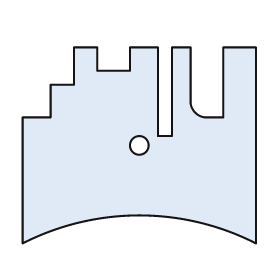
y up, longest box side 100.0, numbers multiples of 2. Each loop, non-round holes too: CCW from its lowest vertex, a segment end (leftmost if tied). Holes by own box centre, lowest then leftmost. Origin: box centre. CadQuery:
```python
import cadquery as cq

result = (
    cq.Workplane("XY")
    .moveTo(-50.0, -42.0)
    .threePointArc((0.0, -30.0), (50.0, -42.0))
    .lineTo(50.0, 42.0)
    .lineTo(36.0, 42.0)
    .lineTo(36.0, 12.0)
    .lineTo(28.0, 12.0)
    .threePointArc((24.0, 14.0), (22.0, 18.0))
    .lineTo(22.0, 42.0)
    .lineTo(14.0, 42.0)
    .lineTo(14.0, 4.0)
    .lineTo(8.0, 4.0)
    .lineTo(8.0, 42.0)
    .lineTo(-4.0, 42.0)
    .lineTo(-4.0, 32.0)
    .lineTo(-18.0, 32.0)
    .lineTo(-18.0, 42.0)
    .lineTo(-28.0, 42.0)
    .lineTo(-28.0, 26.0)
    .lineTo(-38.0, 26.0)
    .lineTo(-38.0, 12.0)
    .lineTo(-50.0, 12.0)
    .close()
    .moveTo(0.0, 0.0)
    .circle(4.0)
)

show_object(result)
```